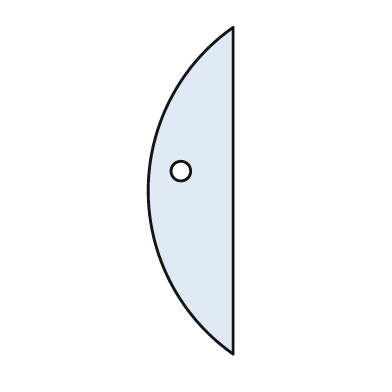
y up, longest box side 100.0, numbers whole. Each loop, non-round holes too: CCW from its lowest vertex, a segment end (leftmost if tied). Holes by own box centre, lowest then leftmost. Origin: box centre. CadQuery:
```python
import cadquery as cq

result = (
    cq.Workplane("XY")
    .moveTo(13.0, -50.0)
    .lineTo(13.0, 50.0)
    .threePointArc((-13.0, 0.0), (13.0, -50.0))
    .close()
    .moveTo(-3.0, 6.0)
    .circle(3.0)
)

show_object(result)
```